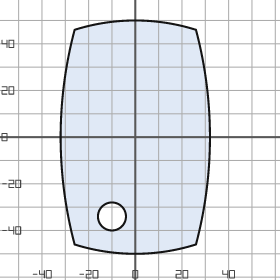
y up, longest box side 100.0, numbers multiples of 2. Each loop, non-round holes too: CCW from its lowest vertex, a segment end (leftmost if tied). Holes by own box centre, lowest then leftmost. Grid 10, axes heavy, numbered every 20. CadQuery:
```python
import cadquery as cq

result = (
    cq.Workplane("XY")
    .moveTo(-26.0, -46.0)
    .threePointArc((0.0, -50.0), (26.0, -46.0))
    .threePointArc((32.0, 0.0), (26.0, 46.0))
    .threePointArc((0.0, 50.0), (-26.0, 46.0))
    .threePointArc((-32.0, 0.0), (-26.0, -46.0))
    .close()
    .moveTo(-10.0, -34.0)
    .circle(6.0)
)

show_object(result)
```